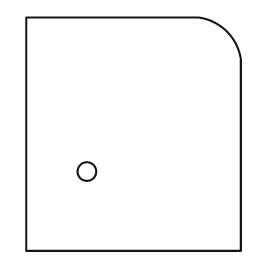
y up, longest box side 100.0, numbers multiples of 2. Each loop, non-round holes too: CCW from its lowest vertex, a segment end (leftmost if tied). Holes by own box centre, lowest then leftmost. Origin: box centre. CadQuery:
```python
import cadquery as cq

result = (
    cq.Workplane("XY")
    .moveTo(-46.0, -50.0)
    .lineTo(46.0, -50.0)
    .lineTo(46.0, 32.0)
    .threePointArc((40.0, 44.0), (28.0, 50.0))
    .lineTo(-46.0, 50.0)
    .close()
    .moveTo(-20.0, -16.0)
    .circle(4.0)
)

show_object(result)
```